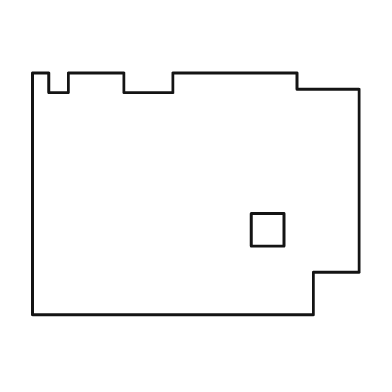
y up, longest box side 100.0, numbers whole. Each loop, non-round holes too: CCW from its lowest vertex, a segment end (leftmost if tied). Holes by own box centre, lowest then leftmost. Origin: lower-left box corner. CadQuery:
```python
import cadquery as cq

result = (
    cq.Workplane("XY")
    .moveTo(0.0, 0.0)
    .lineTo(86.0, 0.0)
    .lineTo(86.0, 13.0)
    .lineTo(100.0, 13.0)
    .lineTo(100.0, 69.0)
    .lineTo(81.0, 69.0)
    .lineTo(81.0, 74.0)
    .lineTo(43.0, 74.0)
    .lineTo(43.0, 68.0)
    .lineTo(28.0, 68.0)
    .lineTo(28.0, 74.0)
    .lineTo(11.0, 74.0)
    .lineTo(11.0, 68.0)
    .lineTo(5.0, 68.0)
    .lineTo(5.0, 74.0)
    .lineTo(0.0, 74.0)
    .close()
    .moveTo(67.0, 21.0)
    .lineTo(77.0, 21.0)
    .lineTo(77.0, 31.0)
    .lineTo(67.0, 31.0)
    .close()
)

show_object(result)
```